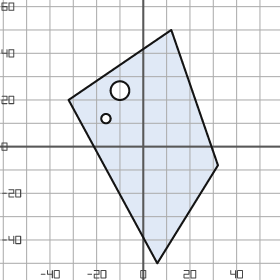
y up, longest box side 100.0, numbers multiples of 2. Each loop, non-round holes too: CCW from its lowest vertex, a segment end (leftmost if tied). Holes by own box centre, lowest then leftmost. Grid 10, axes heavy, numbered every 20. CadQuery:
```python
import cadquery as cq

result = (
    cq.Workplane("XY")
    .moveTo(6.0, -50.0)
    .lineTo(32.0, -8.0)
    .lineTo(12.0, 50.0)
    .lineTo(-32.0, 20.0)
    .close()
    .moveTo(-16.0, 12.0)
    .circle(2.0)
    .moveTo(-10.0, 24.0)
    .circle(4.0)
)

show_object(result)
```